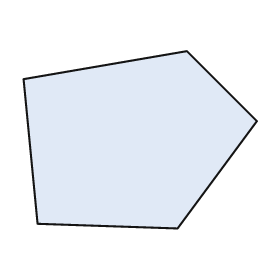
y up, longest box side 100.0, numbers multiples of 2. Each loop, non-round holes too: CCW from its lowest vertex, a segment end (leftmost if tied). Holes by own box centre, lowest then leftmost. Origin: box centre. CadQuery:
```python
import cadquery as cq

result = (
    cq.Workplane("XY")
    .moveTo(16.0, -38.0)
    .lineTo(50.0, 8.0)
    .lineTo(20.0, 38.0)
    .lineTo(-50.0, 26.0)
    .lineTo(-44.0, -36.0)
    .close()
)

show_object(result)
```